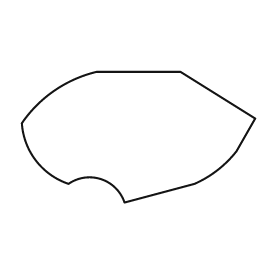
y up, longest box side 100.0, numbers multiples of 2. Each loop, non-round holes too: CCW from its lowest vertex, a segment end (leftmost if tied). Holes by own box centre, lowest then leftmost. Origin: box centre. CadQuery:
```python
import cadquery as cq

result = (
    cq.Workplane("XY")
    .moveTo(-6.0, -28.0)
    .lineTo(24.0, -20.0)
    .threePointArc((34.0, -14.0), (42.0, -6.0))
    .lineTo(50.0, 8.0)
    .lineTo(18.0, 28.0)
    .lineTo(-18.0, 28.0)
    .threePointArc((-36.0, 20.0), (-50.0, 6.0))
    .threePointArc((-44.0, -10.0), (-30.0, -20.0))
    .threePointArc((-16.0, -18.0), (-6.0, -28.0))
    .close()
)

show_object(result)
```